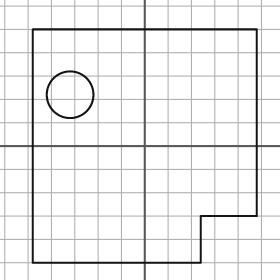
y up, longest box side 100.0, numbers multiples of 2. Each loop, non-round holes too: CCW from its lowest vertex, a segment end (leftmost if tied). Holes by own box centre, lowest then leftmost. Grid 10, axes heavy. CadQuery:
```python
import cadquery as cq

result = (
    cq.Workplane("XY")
    .moveTo(-48.0, -50.0)
    .lineTo(24.0, -50.0)
    .lineTo(24.0, -30.0)
    .lineTo(48.0, -30.0)
    .lineTo(48.0, 50.0)
    .lineTo(-48.0, 50.0)
    .close()
    .moveTo(-32.0, 22.0)
    .circle(10.0)
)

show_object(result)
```